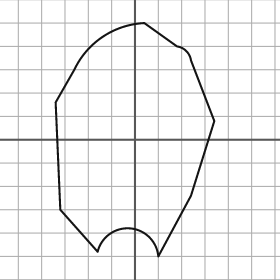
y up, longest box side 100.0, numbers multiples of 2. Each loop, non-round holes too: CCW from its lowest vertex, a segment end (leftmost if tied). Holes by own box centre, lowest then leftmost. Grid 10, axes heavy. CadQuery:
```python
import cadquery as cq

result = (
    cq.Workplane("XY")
    .moveTo(10.0, -50.0)
    .lineTo(24.0, -24.0)
    .lineTo(34.0, 8.0)
    .lineTo(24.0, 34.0)
    .threePointArc((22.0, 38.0), (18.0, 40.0))
    .lineTo(4.0, 50.0)
    .threePointArc((-14.0, 44.0), (-26.0, 30.0))
    .lineTo(-34.0, 16.0)
    .lineTo(-32.0, -30.0)
    .lineTo(-16.0, -48.0)
    .threePointArc((-2.0, -38.0), (10.0, -50.0))
    .close()
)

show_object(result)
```